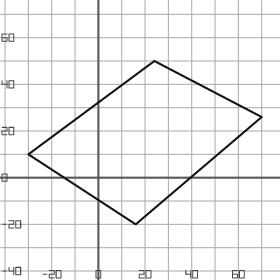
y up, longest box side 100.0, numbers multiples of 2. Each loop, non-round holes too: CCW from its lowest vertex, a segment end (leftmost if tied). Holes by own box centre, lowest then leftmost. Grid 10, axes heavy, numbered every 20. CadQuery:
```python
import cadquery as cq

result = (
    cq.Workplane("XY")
    .moveTo(16.0, -20.0)
    .lineTo(70.0, 26.0)
    .lineTo(24.0, 50.0)
    .lineTo(-30.0, 10.0)
    .close()
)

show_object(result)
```